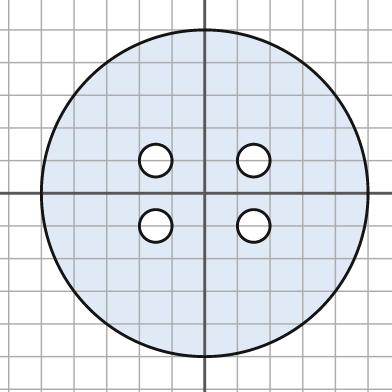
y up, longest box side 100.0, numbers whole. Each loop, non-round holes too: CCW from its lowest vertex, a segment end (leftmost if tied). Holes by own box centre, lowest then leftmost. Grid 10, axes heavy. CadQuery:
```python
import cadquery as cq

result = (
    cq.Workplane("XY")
    .moveTo(0.0, 0.0)
    .circle(50.0)
    .moveTo(-15.0, -10.0)
    .circle(5.0)
    .moveTo(15.0, -10.0)
    .circle(5.0)
    .moveTo(-15.0, 10.0)
    .circle(5.0)
    .moveTo(15.0, 10.0)
    .circle(5.0)
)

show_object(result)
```